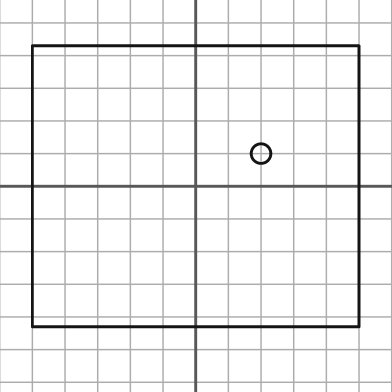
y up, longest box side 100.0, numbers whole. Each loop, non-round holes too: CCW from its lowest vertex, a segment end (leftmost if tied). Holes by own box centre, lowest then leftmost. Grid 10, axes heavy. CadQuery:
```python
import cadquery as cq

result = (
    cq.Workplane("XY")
    .moveTo(-50.0, -43.0)
    .lineTo(50.0, -43.0)
    .lineTo(50.0, 43.0)
    .lineTo(-50.0, 43.0)
    .close()
    .moveTo(20.0, 10.0)
    .circle(3.0)
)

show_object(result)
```